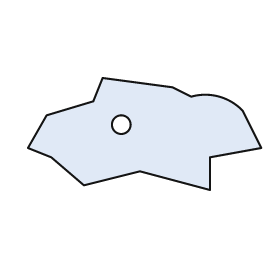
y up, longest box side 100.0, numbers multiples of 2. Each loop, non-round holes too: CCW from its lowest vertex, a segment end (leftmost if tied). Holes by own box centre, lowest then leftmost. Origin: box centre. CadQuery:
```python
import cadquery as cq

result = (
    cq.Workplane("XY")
    .moveTo(28.0, -24.0)
    .lineTo(28.0, -10.0)
    .lineTo(50.0, -6.0)
    .lineTo(42.0, 10.0)
    .threePointArc((32.0, 16.0), (20.0, 16.0))
    .lineTo(12.0, 20.0)
    .lineTo(-18.0, 24.0)
    .lineTo(-22.0, 14.0)
    .lineTo(-42.0, 8.0)
    .lineTo(-50.0, -6.0)
    .lineTo(-40.0, -10.0)
    .lineTo(-26.0, -22.0)
    .lineTo(-2.0, -16.0)
    .close()
    .moveTo(-10.0, 4.0)
    .circle(4.0)
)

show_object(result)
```